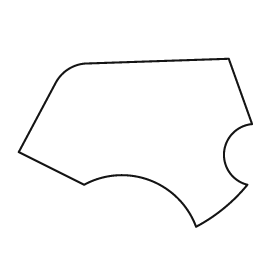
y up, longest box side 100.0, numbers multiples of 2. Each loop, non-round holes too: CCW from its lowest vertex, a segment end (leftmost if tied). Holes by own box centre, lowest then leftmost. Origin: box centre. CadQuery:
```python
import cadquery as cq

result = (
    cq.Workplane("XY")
    .moveTo(26.0, -36.0)
    .threePointArc((38.0, -28.0), (48.0, -18.0))
    .threePointArc((38.0, -4.0), (50.0, 8.0))
    .lineTo(40.0, 36.0)
    .lineTo(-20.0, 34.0)
    .threePointArc((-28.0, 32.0), (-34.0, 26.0))
    .lineTo(-50.0, -4.0)
    .lineTo(-22.0, -18.0)
    .threePointArc((6.0, -16.0), (26.0, -36.0))
    .close()
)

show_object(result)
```